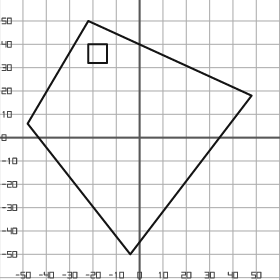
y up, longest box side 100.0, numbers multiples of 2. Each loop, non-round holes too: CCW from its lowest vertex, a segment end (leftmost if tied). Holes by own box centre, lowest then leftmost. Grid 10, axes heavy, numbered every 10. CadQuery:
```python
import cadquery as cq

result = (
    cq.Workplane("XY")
    .moveTo(-4.0, -50.0)
    .lineTo(48.0, 18.0)
    .lineTo(-22.0, 50.0)
    .lineTo(-48.0, 6.0)
    .close()
    .moveTo(-22.0, 32.0)
    .lineTo(-14.0, 32.0)
    .lineTo(-14.0, 40.0)
    .lineTo(-22.0, 40.0)
    .close()
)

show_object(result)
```